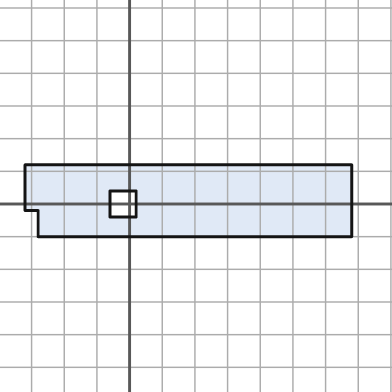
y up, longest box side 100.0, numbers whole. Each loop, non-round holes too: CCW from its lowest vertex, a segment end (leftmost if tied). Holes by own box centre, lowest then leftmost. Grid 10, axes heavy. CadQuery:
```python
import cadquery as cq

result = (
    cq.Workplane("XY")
    .moveTo(-28.0, -10.0)
    .lineTo(68.0, -10.0)
    .lineTo(68.0, 12.0)
    .lineTo(-32.0, 12.0)
    .lineTo(-32.0, -2.0)
    .lineTo(-28.0, -2.0)
    .close()
    .moveTo(-6.0, -4.0)
    .lineTo(2.0, -4.0)
    .lineTo(2.0, 4.0)
    .lineTo(-6.0, 4.0)
    .close()
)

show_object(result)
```